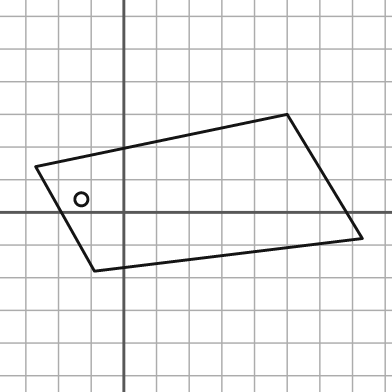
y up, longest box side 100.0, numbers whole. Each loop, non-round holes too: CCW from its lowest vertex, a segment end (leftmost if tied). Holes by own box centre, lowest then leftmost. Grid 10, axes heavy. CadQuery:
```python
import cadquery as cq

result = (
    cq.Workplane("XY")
    .moveTo(-9.0, -18.0)
    .lineTo(73.0, -8.0)
    .lineTo(50.0, 30.0)
    .lineTo(-27.0, 14.0)
    .close()
    .moveTo(-13.0, 4.0)
    .circle(2.0)
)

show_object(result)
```